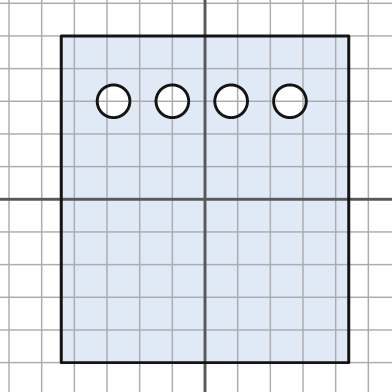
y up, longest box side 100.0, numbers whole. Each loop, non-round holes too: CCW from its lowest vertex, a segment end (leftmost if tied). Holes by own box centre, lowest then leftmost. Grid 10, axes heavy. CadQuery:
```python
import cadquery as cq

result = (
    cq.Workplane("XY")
    .moveTo(-44.0, -50.0)
    .lineTo(44.0, -50.0)
    .lineTo(44.0, 50.0)
    .lineTo(-44.0, 50.0)
    .close()
    .moveTo(-28.0, 30.0)
    .circle(5.0)
    .moveTo(-10.0, 30.0)
    .circle(5.0)
    .moveTo(8.0, 30.0)
    .circle(5.0)
    .moveTo(26.0, 30.0)
    .circle(5.0)
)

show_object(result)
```